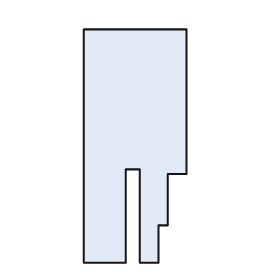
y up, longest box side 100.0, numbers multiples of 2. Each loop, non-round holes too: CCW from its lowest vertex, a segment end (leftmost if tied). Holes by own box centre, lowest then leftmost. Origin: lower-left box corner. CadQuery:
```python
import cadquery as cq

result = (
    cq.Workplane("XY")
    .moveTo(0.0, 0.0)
    .lineTo(18.0, 0.0)
    .lineTo(18.0, 40.0)
    .lineTo(24.0, 40.0)
    .lineTo(24.0, 0.0)
    .lineTo(32.0, 0.0)
    .lineTo(32.0, 16.0)
    .lineTo(36.0, 16.0)
    .lineTo(36.0, 38.0)
    .lineTo(44.0, 38.0)
    .lineTo(44.0, 100.0)
    .lineTo(0.0, 100.0)
    .close()
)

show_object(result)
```